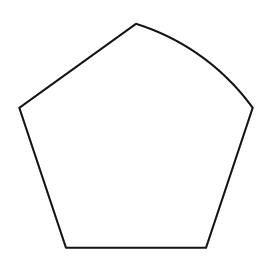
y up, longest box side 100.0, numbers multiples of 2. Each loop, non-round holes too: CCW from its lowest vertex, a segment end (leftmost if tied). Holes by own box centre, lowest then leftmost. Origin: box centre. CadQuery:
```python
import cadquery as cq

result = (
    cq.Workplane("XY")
    .moveTo(-30.0, -48.0)
    .lineTo(30.0, -48.0)
    .lineTo(50.0, 12.0)
    .threePointArc((28.0, 34.0), (0.0, 48.0))
    .lineTo(-50.0, 12.0)
    .close()
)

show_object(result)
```